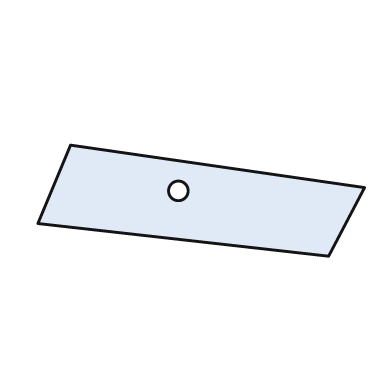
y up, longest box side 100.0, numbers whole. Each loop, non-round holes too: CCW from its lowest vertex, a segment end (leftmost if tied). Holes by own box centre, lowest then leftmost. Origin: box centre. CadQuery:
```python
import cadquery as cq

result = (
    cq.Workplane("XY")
    .moveTo(39.0, -17.0)
    .lineTo(50.0, 4.0)
    .lineTo(-40.0, 17.0)
    .lineTo(-50.0, -7.0)
    .close()
    .moveTo(-7.0, 3.0)
    .circle(3.0)
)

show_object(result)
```